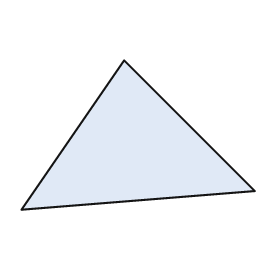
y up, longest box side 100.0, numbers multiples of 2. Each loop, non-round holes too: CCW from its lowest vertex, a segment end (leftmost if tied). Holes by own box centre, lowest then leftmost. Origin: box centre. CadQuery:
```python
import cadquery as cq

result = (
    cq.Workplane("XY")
    .moveTo(-50.0, -32.0)
    .lineTo(50.0, -24.0)
    .lineTo(-6.0, 32.0)
    .close()
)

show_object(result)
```